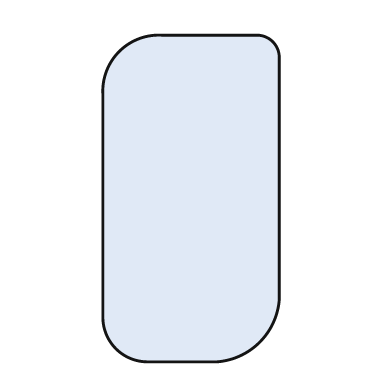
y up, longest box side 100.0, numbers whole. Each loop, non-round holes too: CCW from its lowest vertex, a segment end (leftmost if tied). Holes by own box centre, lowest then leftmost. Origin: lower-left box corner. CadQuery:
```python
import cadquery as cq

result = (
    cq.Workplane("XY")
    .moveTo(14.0, 0.0)
    .lineTo(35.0, 0.0)
    .threePointArc((48.0, 6.0), (54.0, 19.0))
    .lineTo(54.0, 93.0)
    .threePointArc((52.0, 98.0), (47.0, 100.0))
    .lineTo(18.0, 100.0)
    .threePointArc((5.0, 95.0), (0.0, 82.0))
    .lineTo(0.0, 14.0)
    .threePointArc((4.0, 4.0), (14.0, 0.0))
    .close()
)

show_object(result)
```